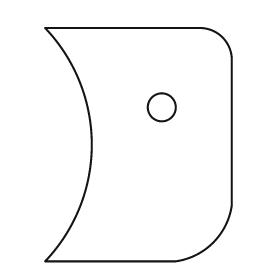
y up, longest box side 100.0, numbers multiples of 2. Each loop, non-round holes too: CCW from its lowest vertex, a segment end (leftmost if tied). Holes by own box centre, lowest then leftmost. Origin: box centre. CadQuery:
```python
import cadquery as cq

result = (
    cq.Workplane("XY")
    .moveTo(-40.0, -50.0)
    .lineTo(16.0, -50.0)
    .threePointArc((32.0, -42.0), (40.0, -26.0))
    .lineTo(40.0, 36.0)
    .threePointArc((36.0, 46.0), (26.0, 50.0))
    .lineTo(-40.0, 50.0)
    .threePointArc((-20.0, 0.0), (-40.0, -50.0))
    .close()
    .moveTo(10.0, 16.0)
    .circle(6.0)
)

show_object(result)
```